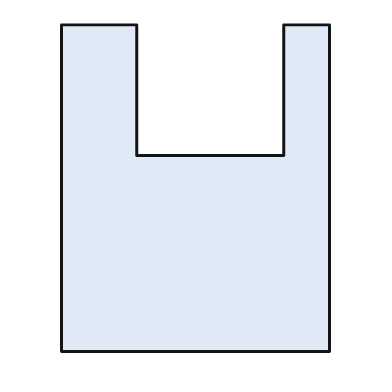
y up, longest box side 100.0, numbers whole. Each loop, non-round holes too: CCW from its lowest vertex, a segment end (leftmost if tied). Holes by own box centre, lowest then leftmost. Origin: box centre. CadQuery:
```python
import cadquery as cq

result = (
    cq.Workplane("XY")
    .moveTo(-41.0, -50.0)
    .lineTo(41.0, -50.0)
    .lineTo(41.0, 50.0)
    .lineTo(27.0, 50.0)
    .lineTo(27.0, 10.0)
    .lineTo(-18.0, 10.0)
    .lineTo(-18.0, 50.0)
    .lineTo(-41.0, 50.0)
    .close()
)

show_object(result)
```